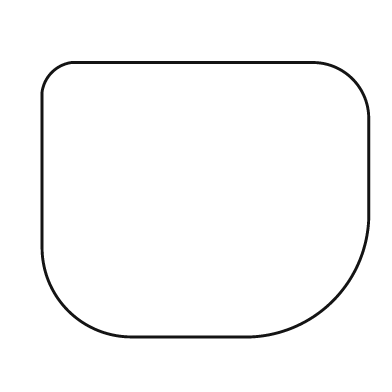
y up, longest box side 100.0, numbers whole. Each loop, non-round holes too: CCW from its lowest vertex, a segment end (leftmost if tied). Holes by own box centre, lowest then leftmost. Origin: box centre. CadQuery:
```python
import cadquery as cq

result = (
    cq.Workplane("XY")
    .moveTo(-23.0, -42.0)
    .lineTo(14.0, -42.0)
    .threePointArc((39.0, -31.0), (50.0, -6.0))
    .lineTo(50.0, 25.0)
    .threePointArc((45.0, 37.0), (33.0, 42.0))
    .lineTo(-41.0, 42.0)
    .threePointArc((-47.0, 39.0), (-50.0, 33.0))
    .lineTo(-50.0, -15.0)
    .threePointArc((-42.0, -34.0), (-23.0, -42.0))
    .close()
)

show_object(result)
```